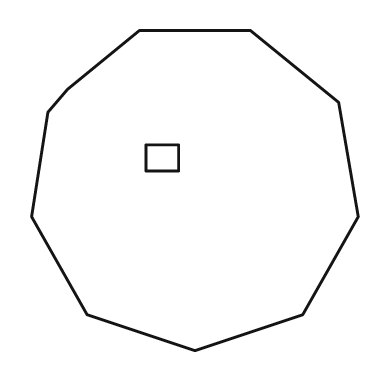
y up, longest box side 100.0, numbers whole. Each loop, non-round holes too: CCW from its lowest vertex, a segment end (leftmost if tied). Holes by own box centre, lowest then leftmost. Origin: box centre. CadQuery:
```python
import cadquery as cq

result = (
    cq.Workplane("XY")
    .moveTo(0.0, -49.0)
    .lineTo(33.0, -38.0)
    .lineTo(50.0, -8.0)
    .lineTo(44.0, 27.0)
    .lineTo(17.0, 49.0)
    .lineTo(-17.0, 49.0)
    .lineTo(-39.0, 31.0)
    .lineTo(-45.0, 24.0)
    .lineTo(-50.0, -8.0)
    .lineTo(-33.0, -38.0)
    .close()
    .moveTo(-15.0, 6.0)
    .lineTo(-5.0, 6.0)
    .lineTo(-5.0, 14.0)
    .lineTo(-15.0, 14.0)
    .close()
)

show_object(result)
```